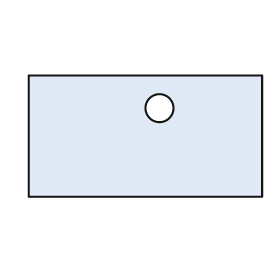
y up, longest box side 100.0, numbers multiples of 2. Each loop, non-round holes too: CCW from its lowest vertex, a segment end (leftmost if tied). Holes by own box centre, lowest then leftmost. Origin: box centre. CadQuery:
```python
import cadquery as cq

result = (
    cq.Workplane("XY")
    .moveTo(-50.0, -26.0)
    .lineTo(50.0, -26.0)
    .lineTo(50.0, 26.0)
    .lineTo(-50.0, 26.0)
    .close()
    .moveTo(6.0, 12.0)
    .circle(6.0)
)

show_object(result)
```